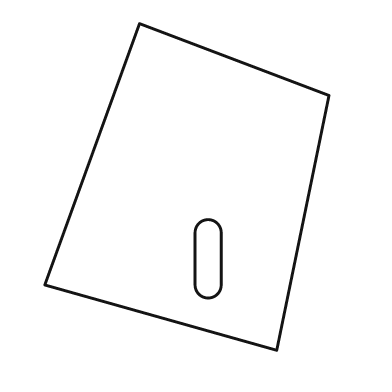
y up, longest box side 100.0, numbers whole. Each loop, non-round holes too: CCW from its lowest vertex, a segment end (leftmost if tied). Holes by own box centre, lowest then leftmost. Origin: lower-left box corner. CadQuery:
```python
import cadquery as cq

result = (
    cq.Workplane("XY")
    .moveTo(71.0, 0.0)
    .lineTo(87.0, 78.0)
    .lineTo(29.0, 100.0)
    .lineTo(0.0, 20.0)
    .close()
    .moveTo(46.0, 20.0)
    .threePointArc((50.0, 16.0), (54.0, 20.0))
    .lineTo(54.0, 36.0)
    .threePointArc((50.0, 40.0), (46.0, 36.0))
    .close()
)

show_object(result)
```